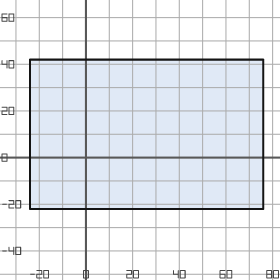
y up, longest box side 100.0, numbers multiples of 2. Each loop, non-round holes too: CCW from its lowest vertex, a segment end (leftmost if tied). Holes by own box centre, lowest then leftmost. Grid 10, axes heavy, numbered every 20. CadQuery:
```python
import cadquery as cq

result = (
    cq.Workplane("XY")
    .moveTo(-24.0, -22.0)
    .lineTo(76.0, -22.0)
    .lineTo(76.0, 42.0)
    .lineTo(-24.0, 42.0)
    .close()
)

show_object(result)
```